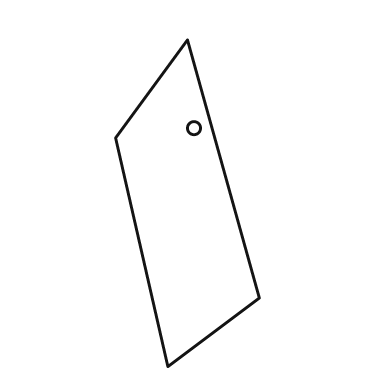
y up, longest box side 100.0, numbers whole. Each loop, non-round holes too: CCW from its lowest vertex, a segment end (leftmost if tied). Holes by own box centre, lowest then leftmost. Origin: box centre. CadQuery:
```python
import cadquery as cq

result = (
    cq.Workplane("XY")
    .moveTo(-6.0, -50.0)
    .lineTo(22.0, -29.0)
    .lineTo(0.0, 50.0)
    .lineTo(-22.0, 20.0)
    .close()
    .moveTo(2.0, 23.0)
    .circle(2.0)
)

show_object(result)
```